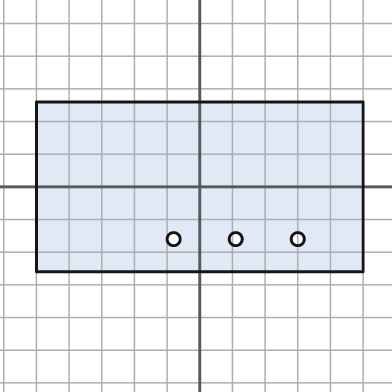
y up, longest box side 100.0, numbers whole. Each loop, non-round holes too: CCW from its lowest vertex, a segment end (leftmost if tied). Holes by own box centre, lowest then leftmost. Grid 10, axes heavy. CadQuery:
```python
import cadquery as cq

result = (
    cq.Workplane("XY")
    .moveTo(-50.0, -26.0)
    .lineTo(50.0, -26.0)
    .lineTo(50.0, 26.0)
    .lineTo(-50.0, 26.0)
    .close()
    .moveTo(-8.0, -16.0)
    .circle(2.0)
    .moveTo(11.0, -16.0)
    .circle(2.0)
    .moveTo(30.0, -16.0)
    .circle(2.0)
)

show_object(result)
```